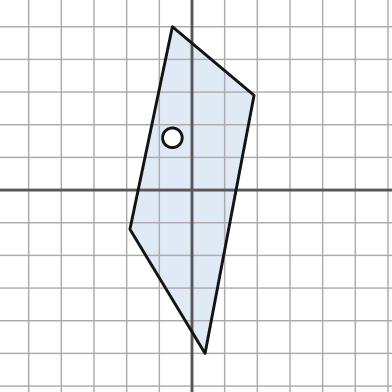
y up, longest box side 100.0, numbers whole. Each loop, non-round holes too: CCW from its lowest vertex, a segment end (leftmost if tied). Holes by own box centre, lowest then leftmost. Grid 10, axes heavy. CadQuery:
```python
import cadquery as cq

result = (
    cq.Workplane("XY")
    .moveTo(4.0, -50.0)
    .lineTo(19.0, 29.0)
    .lineTo(-6.0, 50.0)
    .lineTo(-19.0, -12.0)
    .close()
    .moveTo(-6.0, 16.0)
    .circle(3.0)
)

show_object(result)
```